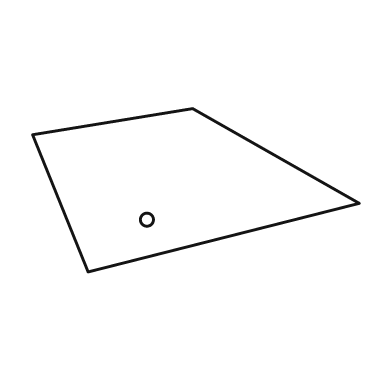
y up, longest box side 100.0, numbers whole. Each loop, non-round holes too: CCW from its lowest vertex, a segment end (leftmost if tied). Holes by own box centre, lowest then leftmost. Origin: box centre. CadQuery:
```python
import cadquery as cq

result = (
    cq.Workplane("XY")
    .moveTo(-33.0, -25.0)
    .lineTo(50.0, -4.0)
    .lineTo(-1.0, 25.0)
    .lineTo(-50.0, 17.0)
    .close()
    .moveTo(-15.0, -9.0)
    .circle(2.0)
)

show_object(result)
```